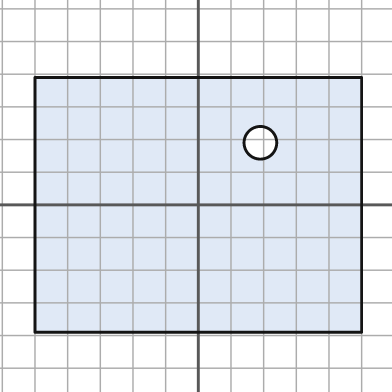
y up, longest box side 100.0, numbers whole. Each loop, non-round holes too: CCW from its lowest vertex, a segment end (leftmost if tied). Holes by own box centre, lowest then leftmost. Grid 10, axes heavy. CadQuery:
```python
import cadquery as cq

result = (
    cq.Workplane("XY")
    .moveTo(-50.0, -39.0)
    .lineTo(50.0, -39.0)
    .lineTo(50.0, 39.0)
    .lineTo(-50.0, 39.0)
    .close()
    .moveTo(19.0, 19.0)
    .circle(5.0)
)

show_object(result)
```